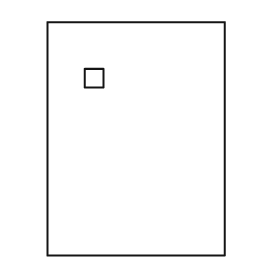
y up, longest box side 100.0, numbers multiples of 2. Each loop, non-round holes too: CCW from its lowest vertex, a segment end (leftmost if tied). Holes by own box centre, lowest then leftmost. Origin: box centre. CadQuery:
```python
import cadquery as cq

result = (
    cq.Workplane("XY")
    .moveTo(-38.0, -50.0)
    .lineTo(38.0, -50.0)
    .lineTo(38.0, 50.0)
    .lineTo(-38.0, 50.0)
    .close()
    .moveTo(-22.0, 22.0)
    .lineTo(-14.0, 22.0)
    .lineTo(-14.0, 30.0)
    .lineTo(-22.0, 30.0)
    .close()
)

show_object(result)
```